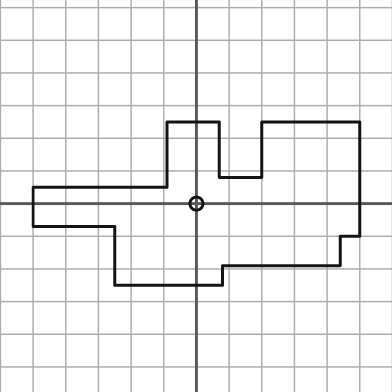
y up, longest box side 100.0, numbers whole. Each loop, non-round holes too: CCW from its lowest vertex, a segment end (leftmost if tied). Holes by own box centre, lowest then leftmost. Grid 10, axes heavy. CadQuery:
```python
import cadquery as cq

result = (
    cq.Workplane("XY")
    .moveTo(-25.0, -25.0)
    .lineTo(8.0, -25.0)
    .lineTo(8.0, -19.0)
    .lineTo(44.0, -19.0)
    .lineTo(44.0, -10.0)
    .lineTo(50.0, -10.0)
    .lineTo(50.0, 25.0)
    .lineTo(20.0, 25.0)
    .lineTo(20.0, 8.0)
    .lineTo(7.0, 8.0)
    .lineTo(7.0, 25.0)
    .lineTo(-9.0, 25.0)
    .lineTo(-9.0, 5.0)
    .lineTo(-50.0, 5.0)
    .lineTo(-50.0, -7.0)
    .lineTo(-25.0, -7.0)
    .close()
    .moveTo(0.0, 0.0)
    .circle(2.0)
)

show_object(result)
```